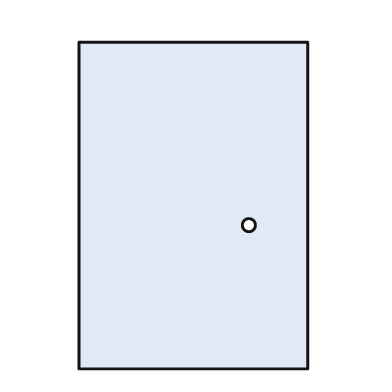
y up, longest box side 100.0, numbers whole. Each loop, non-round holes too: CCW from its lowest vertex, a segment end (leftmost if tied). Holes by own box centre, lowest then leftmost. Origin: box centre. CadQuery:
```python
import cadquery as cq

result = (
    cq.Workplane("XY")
    .moveTo(-35.0, -50.0)
    .lineTo(35.0, -50.0)
    .lineTo(35.0, 50.0)
    .lineTo(-35.0, 50.0)
    .close()
    .moveTo(17.0, -6.0)
    .circle(2.0)
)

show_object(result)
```